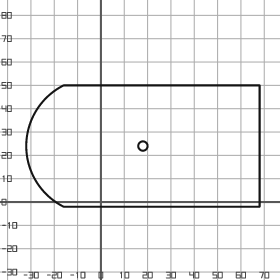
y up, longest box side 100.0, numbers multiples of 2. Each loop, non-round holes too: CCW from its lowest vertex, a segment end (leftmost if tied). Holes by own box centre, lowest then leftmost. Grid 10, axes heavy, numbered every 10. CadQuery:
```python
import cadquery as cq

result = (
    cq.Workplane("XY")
    .moveTo(-16.0, -2.0)
    .lineTo(68.0, -2.0)
    .lineTo(68.0, 50.0)
    .lineTo(-16.0, 50.0)
    .threePointArc((-32.0, 24.0), (-16.0, -2.0))
    .close()
    .moveTo(18.0, 24.0)
    .circle(2.0)
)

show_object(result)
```